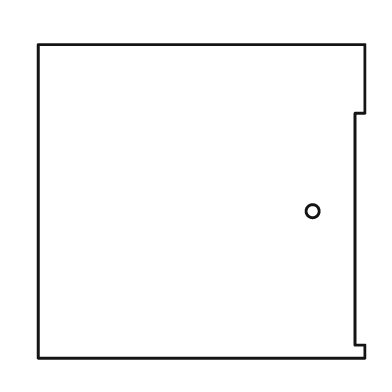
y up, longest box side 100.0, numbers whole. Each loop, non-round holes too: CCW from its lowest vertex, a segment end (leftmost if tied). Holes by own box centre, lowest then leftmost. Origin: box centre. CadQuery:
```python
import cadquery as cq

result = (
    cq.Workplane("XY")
    .moveTo(-50.0, -48.0)
    .lineTo(50.0, -48.0)
    .lineTo(50.0, -44.0)
    .lineTo(47.0, -44.0)
    .lineTo(47.0, 27.0)
    .lineTo(50.0, 27.0)
    .lineTo(50.0, 48.0)
    .lineTo(-50.0, 48.0)
    .close()
    .moveTo(34.0, -3.0)
    .circle(2.0)
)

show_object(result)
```